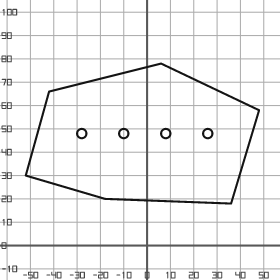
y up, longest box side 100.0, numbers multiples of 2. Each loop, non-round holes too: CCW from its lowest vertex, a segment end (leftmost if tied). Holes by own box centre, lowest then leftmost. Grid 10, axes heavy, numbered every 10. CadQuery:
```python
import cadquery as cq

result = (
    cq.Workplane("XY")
    .moveTo(36.0, 18.0)
    .lineTo(48.0, 58.0)
    .lineTo(6.0, 78.0)
    .lineTo(-42.0, 66.0)
    .lineTo(-52.0, 30.0)
    .lineTo(-18.0, 20.0)
    .close()
    .moveTo(-28.0, 48.0)
    .circle(2.0)
    .moveTo(-10.0, 48.0)
    .circle(2.0)
    .moveTo(8.0, 48.0)
    .circle(2.0)
    .moveTo(26.0, 48.0)
    .circle(2.0)
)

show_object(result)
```